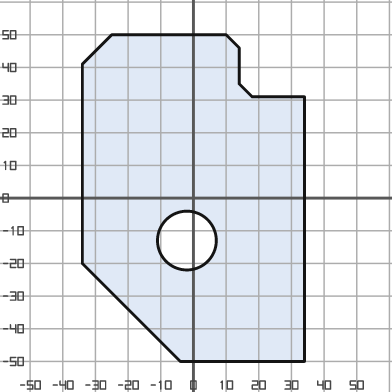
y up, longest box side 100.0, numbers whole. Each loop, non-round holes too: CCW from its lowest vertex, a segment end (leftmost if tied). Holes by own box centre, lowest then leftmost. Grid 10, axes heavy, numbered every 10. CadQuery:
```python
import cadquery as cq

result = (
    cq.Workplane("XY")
    .moveTo(-4.0, -50.0)
    .lineTo(34.0, -50.0)
    .lineTo(34.0, 31.0)
    .lineTo(18.0, 31.0)
    .lineTo(14.0, 35.0)
    .lineTo(14.0, 46.0)
    .lineTo(10.0, 50.0)
    .lineTo(-25.0, 50.0)
    .lineTo(-34.0, 41.0)
    .lineTo(-34.0, -20.0)
    .close()
    .moveTo(-2.0, -13.0)
    .circle(9.0)
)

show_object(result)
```